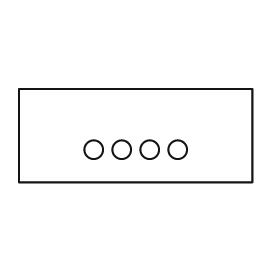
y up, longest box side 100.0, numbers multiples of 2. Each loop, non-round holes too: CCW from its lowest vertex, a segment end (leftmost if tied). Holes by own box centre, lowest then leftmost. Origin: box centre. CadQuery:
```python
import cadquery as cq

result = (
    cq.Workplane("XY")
    .moveTo(-50.0, -20.0)
    .lineTo(50.0, -20.0)
    .lineTo(50.0, 20.0)
    .lineTo(-50.0, 20.0)
    .close()
    .moveTo(-18.0, -6.0)
    .circle(4.0)
    .moveTo(-6.0, -6.0)
    .circle(4.0)
    .moveTo(6.0, -6.0)
    .circle(4.0)
    .moveTo(18.0, -6.0)
    .circle(4.0)
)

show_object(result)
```